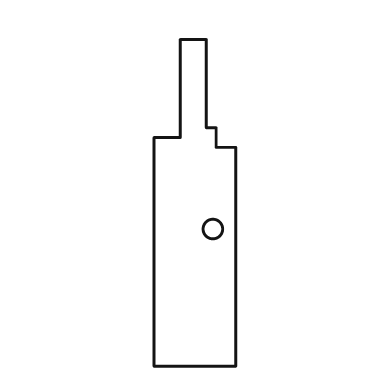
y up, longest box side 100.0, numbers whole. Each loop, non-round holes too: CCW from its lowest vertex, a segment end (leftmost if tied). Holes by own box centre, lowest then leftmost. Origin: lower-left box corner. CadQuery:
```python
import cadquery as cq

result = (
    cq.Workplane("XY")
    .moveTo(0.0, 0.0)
    .lineTo(25.0, 0.0)
    .lineTo(25.0, 67.0)
    .lineTo(19.0, 67.0)
    .lineTo(19.0, 73.0)
    .lineTo(16.0, 73.0)
    .lineTo(16.0, 100.0)
    .lineTo(8.0, 100.0)
    .lineTo(8.0, 70.0)
    .lineTo(0.0, 70.0)
    .close()
    .moveTo(18.0, 42.0)
    .circle(3.0)
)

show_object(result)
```